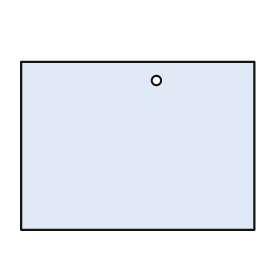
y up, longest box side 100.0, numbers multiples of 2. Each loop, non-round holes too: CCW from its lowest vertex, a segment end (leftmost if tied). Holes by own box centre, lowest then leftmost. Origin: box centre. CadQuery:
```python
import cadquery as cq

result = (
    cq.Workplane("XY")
    .moveTo(-50.0, -36.0)
    .lineTo(50.0, -36.0)
    .lineTo(50.0, 36.0)
    .lineTo(-50.0, 36.0)
    .close()
    .moveTo(8.0, 28.0)
    .circle(2.0)
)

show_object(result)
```